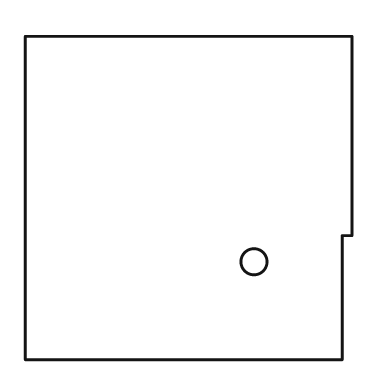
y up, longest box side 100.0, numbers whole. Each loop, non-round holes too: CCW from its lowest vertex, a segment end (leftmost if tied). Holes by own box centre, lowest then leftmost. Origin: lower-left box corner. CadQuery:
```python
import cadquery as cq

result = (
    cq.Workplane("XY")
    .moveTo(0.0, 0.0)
    .lineTo(97.0, 0.0)
    .lineTo(97.0, 38.0)
    .lineTo(100.0, 38.0)
    .lineTo(100.0, 99.0)
    .lineTo(0.0, 99.0)
    .close()
    .moveTo(70.0, 30.0)
    .circle(4.0)
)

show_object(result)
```